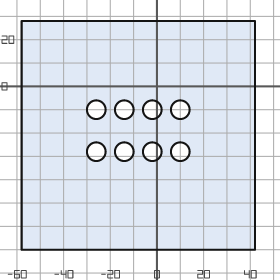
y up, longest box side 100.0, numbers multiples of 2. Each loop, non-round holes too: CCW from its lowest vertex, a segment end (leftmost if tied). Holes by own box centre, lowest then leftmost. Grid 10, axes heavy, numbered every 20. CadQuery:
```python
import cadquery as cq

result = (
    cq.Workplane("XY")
    .moveTo(-58.0, -70.0)
    .lineTo(42.0, -70.0)
    .lineTo(42.0, 28.0)
    .lineTo(-58.0, 28.0)
    .close()
    .moveTo(-26.0, -28.0)
    .circle(4.0)
    .moveTo(-14.0, -28.0)
    .circle(4.0)
    .moveTo(-2.0, -28.0)
    .circle(4.0)
    .moveTo(10.0, -28.0)
    .circle(4.0)
    .moveTo(-26.0, -10.0)
    .circle(4.0)
    .moveTo(-14.0, -10.0)
    .circle(4.0)
    .moveTo(-2.0, -10.0)
    .circle(4.0)
    .moveTo(10.0, -10.0)
    .circle(4.0)
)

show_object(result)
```